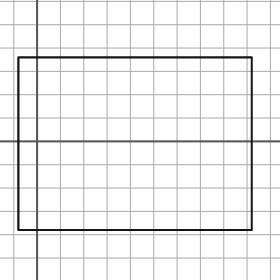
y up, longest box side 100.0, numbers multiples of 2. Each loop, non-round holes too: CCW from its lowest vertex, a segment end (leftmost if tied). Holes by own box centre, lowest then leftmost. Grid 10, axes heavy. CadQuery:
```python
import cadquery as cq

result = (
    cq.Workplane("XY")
    .moveTo(-8.0, -38.0)
    .lineTo(92.0, -38.0)
    .lineTo(92.0, 36.0)
    .lineTo(-8.0, 36.0)
    .close()
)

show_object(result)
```